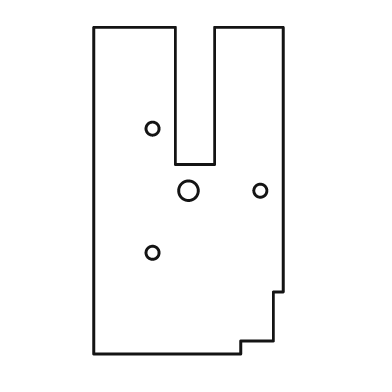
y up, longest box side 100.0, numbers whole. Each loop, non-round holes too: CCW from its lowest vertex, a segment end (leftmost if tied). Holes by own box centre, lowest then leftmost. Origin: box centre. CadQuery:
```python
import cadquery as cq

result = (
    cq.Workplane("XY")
    .moveTo(-29.0, -50.0)
    .lineTo(16.0, -50.0)
    .lineTo(16.0, -46.0)
    .lineTo(26.0, -46.0)
    .lineTo(26.0, -31.0)
    .lineTo(29.0, -31.0)
    .lineTo(29.0, 50.0)
    .lineTo(8.0, 50.0)
    .lineTo(8.0, 8.0)
    .lineTo(-4.0, 8.0)
    .lineTo(-4.0, 50.0)
    .lineTo(-29.0, 50.0)
    .close()
    .moveTo(-11.0, -19.0)
    .circle(2.0)
    .moveTo(0.0, 0.0)
    .circle(3.0)
    .moveTo(22.0, 0.0)
    .circle(2.0)
    .moveTo(-11.0, 19.0)
    .circle(2.0)
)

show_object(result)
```